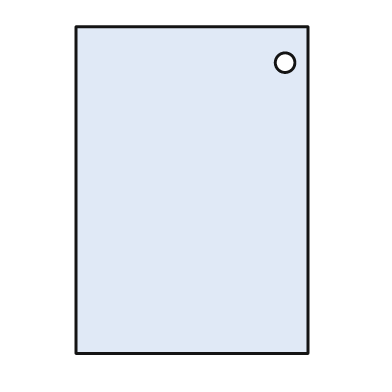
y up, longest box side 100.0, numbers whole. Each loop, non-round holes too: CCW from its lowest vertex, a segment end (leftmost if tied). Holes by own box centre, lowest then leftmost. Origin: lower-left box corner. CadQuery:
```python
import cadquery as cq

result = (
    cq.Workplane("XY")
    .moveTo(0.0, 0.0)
    .lineTo(71.0, 0.0)
    .lineTo(71.0, 100.0)
    .lineTo(0.0, 100.0)
    .close()
    .moveTo(64.0, 89.0)
    .circle(3.0)
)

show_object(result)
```